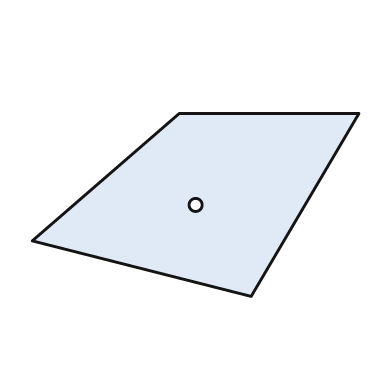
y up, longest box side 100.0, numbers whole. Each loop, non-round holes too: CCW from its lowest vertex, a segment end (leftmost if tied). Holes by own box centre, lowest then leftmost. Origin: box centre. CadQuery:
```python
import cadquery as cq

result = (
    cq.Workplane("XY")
    .moveTo(17.0, -28.0)
    .lineTo(50.0, 28.0)
    .lineTo(-5.0, 28.0)
    .lineTo(-50.0, -11.0)
    .close()
    .moveTo(0.0, 0.0)
    .circle(2.0)
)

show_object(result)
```